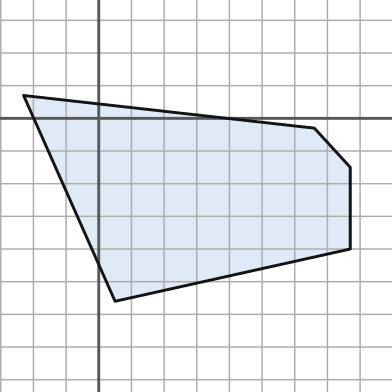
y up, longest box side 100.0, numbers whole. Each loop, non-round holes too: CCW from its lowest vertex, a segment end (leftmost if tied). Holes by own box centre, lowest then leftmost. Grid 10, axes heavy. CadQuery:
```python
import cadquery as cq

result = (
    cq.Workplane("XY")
    .moveTo(5.0, -56.0)
    .lineTo(77.0, -40.0)
    .lineTo(77.0, -15.0)
    .lineTo(66.0, -3.0)
    .lineTo(-23.0, 7.0)
    .close()
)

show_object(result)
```